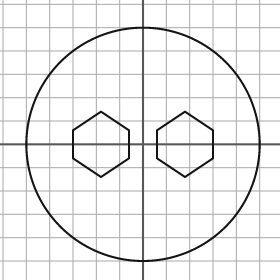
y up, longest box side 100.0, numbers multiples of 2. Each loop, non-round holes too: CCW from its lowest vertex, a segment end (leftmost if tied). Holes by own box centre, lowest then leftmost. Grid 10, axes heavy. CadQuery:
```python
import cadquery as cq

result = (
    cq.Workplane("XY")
    .moveTo(0.0, 0.0)
    .circle(50.0)
    .moveTo(-18.0, -14.0)
    .lineTo(-6.0, -6.0)
    .lineTo(-6.0, 6.0)
    .lineTo(-18.0, 14.0)
    .lineTo(-30.0, 6.0)
    .lineTo(-30.0, -6.0)
    .close()
    .moveTo(18.0, -14.0)
    .lineTo(30.0, -6.0)
    .lineTo(30.0, 6.0)
    .lineTo(18.0, 14.0)
    .lineTo(6.0, 6.0)
    .lineTo(6.0, -6.0)
    .close()
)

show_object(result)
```